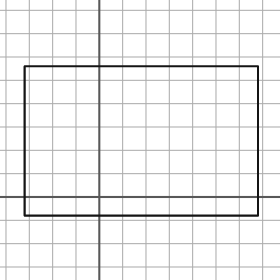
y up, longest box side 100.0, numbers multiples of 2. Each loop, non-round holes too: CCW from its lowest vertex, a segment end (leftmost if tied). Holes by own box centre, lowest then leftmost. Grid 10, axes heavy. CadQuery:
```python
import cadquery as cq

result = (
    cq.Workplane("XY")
    .moveTo(-32.0, -8.0)
    .lineTo(68.0, -8.0)
    .lineTo(68.0, 56.0)
    .lineTo(-32.0, 56.0)
    .close()
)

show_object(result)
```